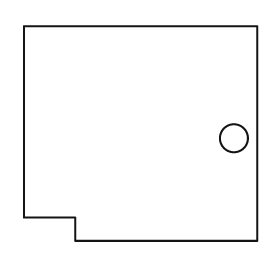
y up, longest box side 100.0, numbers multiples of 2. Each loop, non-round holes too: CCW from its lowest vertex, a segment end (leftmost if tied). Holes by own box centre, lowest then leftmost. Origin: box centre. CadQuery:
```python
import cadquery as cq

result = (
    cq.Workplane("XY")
    .moveTo(-28.0, -46.0)
    .lineTo(50.0, -46.0)
    .lineTo(50.0, 46.0)
    .lineTo(-50.0, 46.0)
    .lineTo(-50.0, -36.0)
    .lineTo(-28.0, -36.0)
    .close()
    .moveTo(40.0, -2.0)
    .circle(6.0)
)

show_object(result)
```